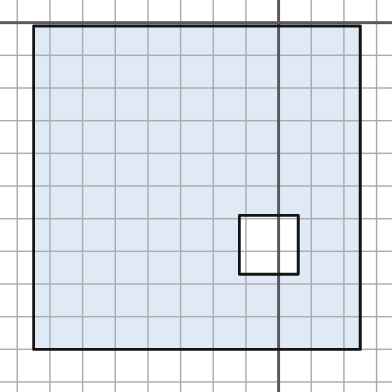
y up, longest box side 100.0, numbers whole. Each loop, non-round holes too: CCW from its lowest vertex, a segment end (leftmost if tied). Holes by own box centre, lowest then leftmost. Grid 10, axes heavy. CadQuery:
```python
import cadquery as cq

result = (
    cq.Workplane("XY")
    .moveTo(-75.0, -100.0)
    .lineTo(25.0, -100.0)
    .lineTo(25.0, -1.0)
    .lineTo(-75.0, -1.0)
    .close()
    .moveTo(-12.0, -77.0)
    .lineTo(6.0, -77.0)
    .lineTo(6.0, -59.0)
    .lineTo(-12.0, -59.0)
    .close()
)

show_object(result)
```